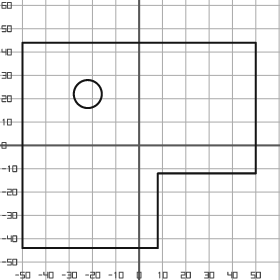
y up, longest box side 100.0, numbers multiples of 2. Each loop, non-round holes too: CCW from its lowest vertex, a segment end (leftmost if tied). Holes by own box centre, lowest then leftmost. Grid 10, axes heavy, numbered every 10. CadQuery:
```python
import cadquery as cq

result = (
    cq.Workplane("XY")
    .moveTo(-50.0, -44.0)
    .lineTo(8.0, -44.0)
    .lineTo(8.0, -12.0)
    .lineTo(50.0, -12.0)
    .lineTo(50.0, 44.0)
    .lineTo(-50.0, 44.0)
    .close()
    .moveTo(-22.0, 22.0)
    .circle(6.0)
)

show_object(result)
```